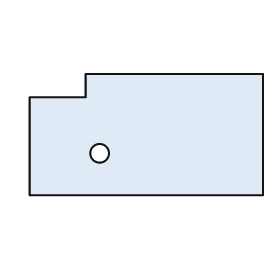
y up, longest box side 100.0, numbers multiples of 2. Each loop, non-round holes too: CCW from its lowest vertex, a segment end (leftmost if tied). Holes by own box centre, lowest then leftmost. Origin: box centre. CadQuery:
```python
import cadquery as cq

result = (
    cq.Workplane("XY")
    .moveTo(-50.0, -26.0)
    .lineTo(50.0, -26.0)
    .lineTo(50.0, 26.0)
    .lineTo(-26.0, 26.0)
    .lineTo(-26.0, 16.0)
    .lineTo(-50.0, 16.0)
    .close()
    .moveTo(-20.0, -8.0)
    .circle(4.0)
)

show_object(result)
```